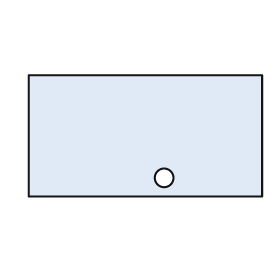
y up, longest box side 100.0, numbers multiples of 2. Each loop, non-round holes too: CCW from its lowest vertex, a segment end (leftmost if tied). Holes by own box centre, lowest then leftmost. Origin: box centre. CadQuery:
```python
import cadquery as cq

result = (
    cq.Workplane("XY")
    .moveTo(-50.0, -26.0)
    .lineTo(50.0, -26.0)
    .lineTo(50.0, 26.0)
    .lineTo(-50.0, 26.0)
    .close()
    .moveTo(8.0, -18.0)
    .circle(4.0)
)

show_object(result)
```